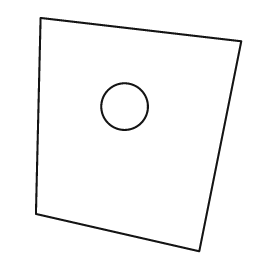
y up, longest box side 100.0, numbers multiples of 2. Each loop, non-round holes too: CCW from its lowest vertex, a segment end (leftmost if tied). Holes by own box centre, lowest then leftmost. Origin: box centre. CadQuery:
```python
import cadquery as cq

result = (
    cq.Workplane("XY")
    .moveTo(26.0, -50.0)
    .lineTo(44.0, 40.0)
    .lineTo(-42.0, 50.0)
    .lineTo(-44.0, -34.0)
    .close()
    .moveTo(-6.0, 12.0)
    .circle(10.0)
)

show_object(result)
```